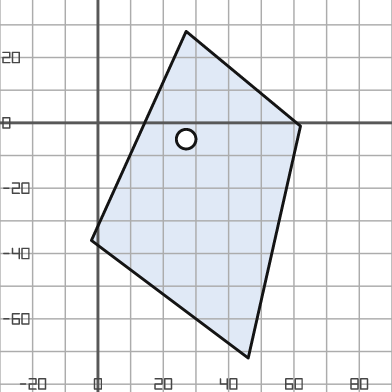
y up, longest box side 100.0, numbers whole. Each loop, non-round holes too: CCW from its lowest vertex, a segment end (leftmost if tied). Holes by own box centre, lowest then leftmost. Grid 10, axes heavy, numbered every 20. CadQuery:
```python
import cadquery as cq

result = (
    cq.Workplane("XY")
    .moveTo(46.0, -72.0)
    .lineTo(62.0, -1.0)
    .lineTo(27.0, 28.0)
    .lineTo(-2.0, -36.0)
    .close()
    .moveTo(27.0, -5.0)
    .circle(3.0)
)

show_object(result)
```